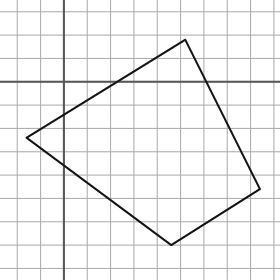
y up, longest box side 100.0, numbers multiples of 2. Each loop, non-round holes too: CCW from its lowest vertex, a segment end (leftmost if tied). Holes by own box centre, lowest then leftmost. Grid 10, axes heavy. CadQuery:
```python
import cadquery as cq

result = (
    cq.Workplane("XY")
    .moveTo(46.0, -70.0)
    .lineTo(84.0, -46.0)
    .lineTo(52.0, 18.0)
    .lineTo(-16.0, -24.0)
    .close()
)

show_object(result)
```